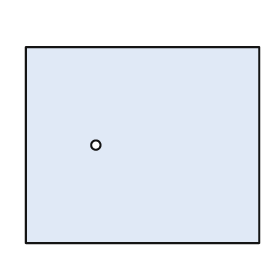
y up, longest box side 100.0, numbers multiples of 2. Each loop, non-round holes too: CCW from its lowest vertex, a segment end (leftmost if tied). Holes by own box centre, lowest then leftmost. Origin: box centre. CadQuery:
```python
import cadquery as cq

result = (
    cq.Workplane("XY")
    .moveTo(-50.0, -42.0)
    .lineTo(50.0, -42.0)
    .lineTo(50.0, 42.0)
    .lineTo(-50.0, 42.0)
    .close()
    .moveTo(-20.0, 0.0)
    .circle(2.0)
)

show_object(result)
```